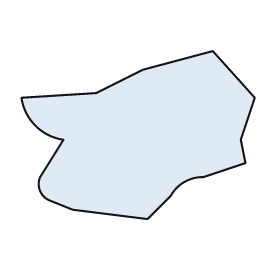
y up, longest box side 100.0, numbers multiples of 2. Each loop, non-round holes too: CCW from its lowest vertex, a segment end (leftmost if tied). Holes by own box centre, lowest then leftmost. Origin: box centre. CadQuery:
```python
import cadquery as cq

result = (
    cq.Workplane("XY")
    .moveTo(4.0, -36.0)
    .lineTo(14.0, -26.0)
    .threePointArc((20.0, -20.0), (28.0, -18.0))
    .lineTo(46.0, -12.0)
    .lineTo(44.0, -2.0)
    .lineTo(50.0, 16.0)
    .lineTo(32.0, 36.0)
    .lineTo(2.0, 28.0)
    .lineTo(-18.0, 18.0)
    .lineTo(-50.0, 16.0)
    .threePointArc((-44.0, 4.0), (-32.0, -2.0))
    .lineTo(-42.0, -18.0)
    .threePointArc((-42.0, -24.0), (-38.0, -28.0))
    .lineTo(-28.0, -32.0)
    .close()
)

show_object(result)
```